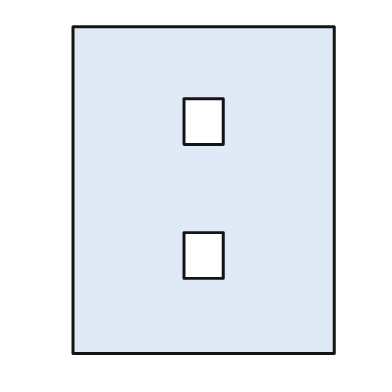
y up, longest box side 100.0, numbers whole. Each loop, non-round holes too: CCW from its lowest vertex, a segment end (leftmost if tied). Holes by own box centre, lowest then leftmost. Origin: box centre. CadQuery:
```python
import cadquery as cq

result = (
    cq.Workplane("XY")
    .moveTo(-40.0, -50.0)
    .lineTo(40.0, -50.0)
    .lineTo(40.0, 50.0)
    .lineTo(-40.0, 50.0)
    .close()
    .moveTo(-6.0, -27.0)
    .lineTo(6.0, -27.0)
    .lineTo(6.0, -13.0)
    .lineTo(-6.0, -13.0)
    .close()
    .moveTo(-6.0, 14.0)
    .lineTo(6.0, 14.0)
    .lineTo(6.0, 28.0)
    .lineTo(-6.0, 28.0)
    .close()
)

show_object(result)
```